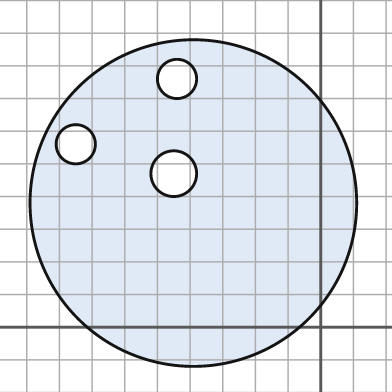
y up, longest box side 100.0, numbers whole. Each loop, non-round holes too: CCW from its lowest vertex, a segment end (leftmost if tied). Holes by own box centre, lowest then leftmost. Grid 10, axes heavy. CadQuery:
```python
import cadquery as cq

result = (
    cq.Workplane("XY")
    .moveTo(-39.0, 38.0)
    .circle(50.0)
    .moveTo(-45.0, 47.0)
    .circle(7.0)
    .moveTo(-75.0, 56.0)
    .circle(6.0)
    .moveTo(-44.0, 76.0)
    .circle(6.0)
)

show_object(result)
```